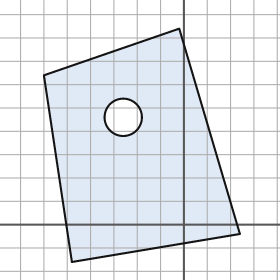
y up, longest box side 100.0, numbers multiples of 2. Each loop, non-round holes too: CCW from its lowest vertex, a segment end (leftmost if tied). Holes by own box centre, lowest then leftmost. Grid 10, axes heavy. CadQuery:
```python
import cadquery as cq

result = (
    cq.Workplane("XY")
    .moveTo(-48.0, -16.0)
    .lineTo(24.0, -4.0)
    .lineTo(-2.0, 84.0)
    .lineTo(-60.0, 64.0)
    .close()
    .moveTo(-26.0, 46.0)
    .circle(8.0)
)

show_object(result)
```